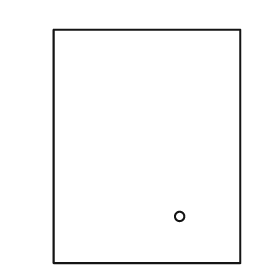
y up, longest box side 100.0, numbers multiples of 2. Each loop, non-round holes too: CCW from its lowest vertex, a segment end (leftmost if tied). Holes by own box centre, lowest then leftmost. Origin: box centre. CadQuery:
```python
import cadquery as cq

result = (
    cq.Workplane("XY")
    .moveTo(-40.0, -50.0)
    .lineTo(40.0, -50.0)
    .lineTo(40.0, 50.0)
    .lineTo(-40.0, 50.0)
    .close()
    .moveTo(14.0, -30.0)
    .circle(2.0)
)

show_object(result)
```